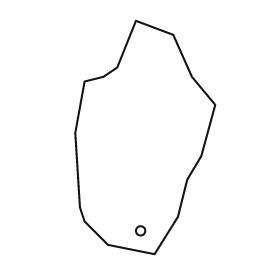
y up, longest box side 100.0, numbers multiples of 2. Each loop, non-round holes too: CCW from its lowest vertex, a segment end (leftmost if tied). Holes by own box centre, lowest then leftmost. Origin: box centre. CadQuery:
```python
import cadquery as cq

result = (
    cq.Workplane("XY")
    .moveTo(4.0, -50.0)
    .lineTo(14.0, -34.0)
    .lineTo(18.0, -18.0)
    .lineTo(24.0, -8.0)
    .lineTo(30.0, 14.0)
    .lineTo(20.0, 26.0)
    .lineTo(12.0, 44.0)
    .lineTo(-4.0, 50.0)
    .lineTo(-12.0, 30.0)
    .lineTo(-18.0, 26.0)
    .lineTo(-26.0, 24.0)
    .lineTo(-30.0, 2.0)
    .lineTo(-28.0, -30.0)
    .lineTo(-26.0, -36.0)
    .lineTo(-16.0, -46.0)
    .close()
    .moveTo(-2.0, -40.0)
    .circle(2.0)
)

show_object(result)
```